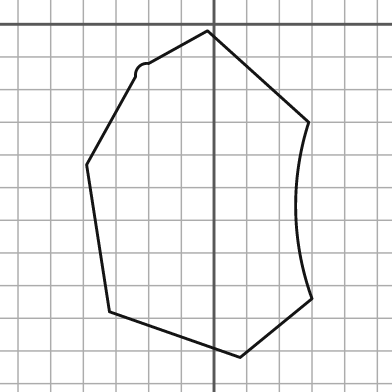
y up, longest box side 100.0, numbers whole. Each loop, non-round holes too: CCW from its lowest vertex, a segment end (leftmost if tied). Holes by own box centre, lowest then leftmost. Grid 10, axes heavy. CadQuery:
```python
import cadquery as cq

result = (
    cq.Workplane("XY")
    .moveTo(8.0, -102.0)
    .lineTo(30.0, -84.0)
    .threePointArc((25.0, -57.0), (29.0, -30.0))
    .lineTo(-2.0, -2.0)
    .lineTo(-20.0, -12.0)
    .threePointArc((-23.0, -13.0), (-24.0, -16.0))
    .lineTo(-39.0, -43.0)
    .lineTo(-32.0, -88.0)
    .close()
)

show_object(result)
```